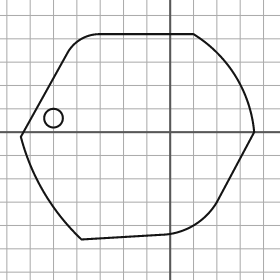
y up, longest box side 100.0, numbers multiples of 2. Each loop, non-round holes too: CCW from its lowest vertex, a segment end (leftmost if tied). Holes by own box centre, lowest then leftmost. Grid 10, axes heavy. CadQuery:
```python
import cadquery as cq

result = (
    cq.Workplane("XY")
    .moveTo(-38.0, -46.0)
    .lineTo(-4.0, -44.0)
    .threePointArc((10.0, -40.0), (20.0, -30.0))
    .lineTo(36.0, 0.0)
    .threePointArc((28.0, 24.0), (10.0, 42.0))
    .lineTo(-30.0, 42.0)
    .threePointArc((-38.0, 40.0), (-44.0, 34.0))
    .lineTo(-64.0, -2.0)
    .threePointArc((-54.0, -26.0), (-38.0, -46.0))
    .close()
    .moveTo(-50.0, 6.0)
    .circle(4.0)
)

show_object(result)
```